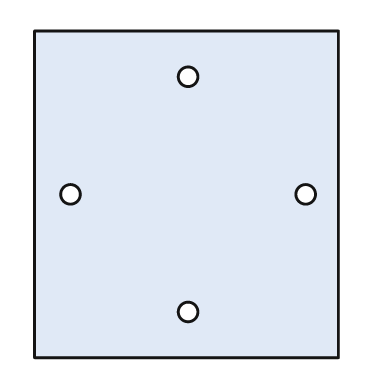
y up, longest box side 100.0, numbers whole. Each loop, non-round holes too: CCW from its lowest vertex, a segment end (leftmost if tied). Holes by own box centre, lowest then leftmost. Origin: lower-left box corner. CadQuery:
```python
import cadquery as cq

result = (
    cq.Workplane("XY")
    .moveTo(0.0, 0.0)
    .lineTo(93.0, 0.0)
    .lineTo(93.0, 100.0)
    .lineTo(0.0, 100.0)
    .close()
    .moveTo(47.0, 14.0)
    .circle(3.0)
    .moveTo(11.0, 50.0)
    .circle(3.0)
    .moveTo(83.0, 50.0)
    .circle(3.0)
    .moveTo(47.0, 86.0)
    .circle(3.0)
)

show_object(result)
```